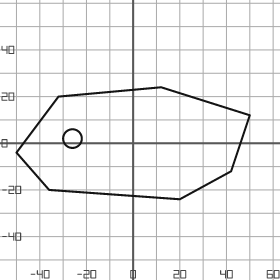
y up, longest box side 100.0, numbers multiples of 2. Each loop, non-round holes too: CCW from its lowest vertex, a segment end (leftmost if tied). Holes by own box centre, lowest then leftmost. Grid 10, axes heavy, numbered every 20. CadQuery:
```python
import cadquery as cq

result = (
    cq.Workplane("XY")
    .moveTo(20.0, -24.0)
    .lineTo(42.0, -12.0)
    .lineTo(50.0, 12.0)
    .lineTo(12.0, 24.0)
    .lineTo(-32.0, 20.0)
    .lineTo(-50.0, -4.0)
    .lineTo(-36.0, -20.0)
    .close()
    .moveTo(-26.0, 2.0)
    .circle(4.0)
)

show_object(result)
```